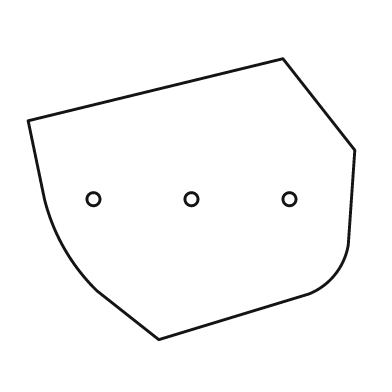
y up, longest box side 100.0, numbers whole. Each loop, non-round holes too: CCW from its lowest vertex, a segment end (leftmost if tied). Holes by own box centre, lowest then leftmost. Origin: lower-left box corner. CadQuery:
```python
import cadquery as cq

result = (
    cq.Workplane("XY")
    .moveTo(40.0, 0.0)
    .lineTo(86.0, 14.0)
    .threePointArc((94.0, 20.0), (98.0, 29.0))
    .lineTo(100.0, 58.0)
    .lineTo(78.0, 86.0)
    .lineTo(0.0, 67.0)
    .lineTo(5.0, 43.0)
    .threePointArc((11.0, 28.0), (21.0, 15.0))
    .close()
    .moveTo(20.0, 43.0)
    .circle(2.0)
    .moveTo(50.0, 43.0)
    .circle(2.0)
    .moveTo(80.0, 43.0)
    .circle(2.0)
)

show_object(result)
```